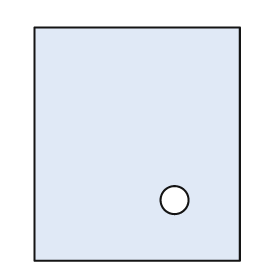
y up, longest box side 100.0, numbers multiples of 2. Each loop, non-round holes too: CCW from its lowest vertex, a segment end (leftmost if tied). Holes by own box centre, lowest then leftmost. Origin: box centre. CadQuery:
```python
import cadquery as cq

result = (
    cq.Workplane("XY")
    .moveTo(-44.0, -50.0)
    .lineTo(44.0, -50.0)
    .lineTo(44.0, 50.0)
    .lineTo(-44.0, 50.0)
    .close()
    .moveTo(16.0, -24.0)
    .circle(6.0)
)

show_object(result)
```